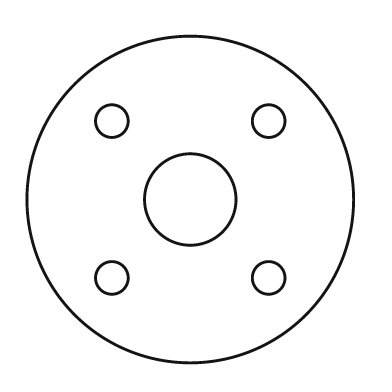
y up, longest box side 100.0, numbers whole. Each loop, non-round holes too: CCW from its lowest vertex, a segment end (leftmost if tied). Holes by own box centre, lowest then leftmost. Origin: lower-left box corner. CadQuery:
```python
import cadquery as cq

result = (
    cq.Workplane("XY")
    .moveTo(50.0, 50.0)
    .circle(50.0)
    .moveTo(26.0, 26.0)
    .circle(5.0)
    .moveTo(74.0, 26.0)
    .circle(5.0)
    .moveTo(50.0, 50.0)
    .circle(14.0)
    .moveTo(26.0, 74.0)
    .circle(5.0)
    .moveTo(74.0, 74.0)
    .circle(5.0)
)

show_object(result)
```